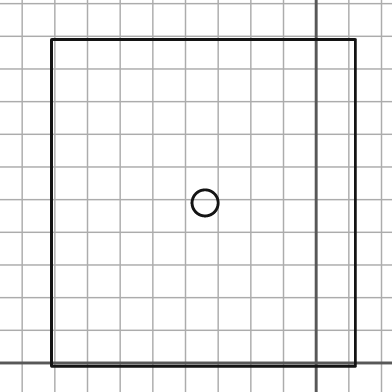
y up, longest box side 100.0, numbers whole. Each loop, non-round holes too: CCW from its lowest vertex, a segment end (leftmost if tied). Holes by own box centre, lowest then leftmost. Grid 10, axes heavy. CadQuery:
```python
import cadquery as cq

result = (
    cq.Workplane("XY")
    .moveTo(-81.0, -1.0)
    .lineTo(12.0, -1.0)
    .lineTo(12.0, 99.0)
    .lineTo(-81.0, 99.0)
    .close()
    .moveTo(-34.0, 49.0)
    .circle(4.0)
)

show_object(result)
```